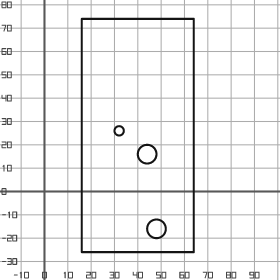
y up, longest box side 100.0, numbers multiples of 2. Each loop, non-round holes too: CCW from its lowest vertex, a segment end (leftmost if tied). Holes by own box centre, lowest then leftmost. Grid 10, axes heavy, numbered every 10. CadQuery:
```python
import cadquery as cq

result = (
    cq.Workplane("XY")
    .moveTo(16.0, -26.0)
    .lineTo(64.0, -26.0)
    .lineTo(64.0, 74.0)
    .lineTo(16.0, 74.0)
    .close()
    .moveTo(48.0, -16.0)
    .circle(4.0)
    .moveTo(44.0, 16.0)
    .circle(4.0)
    .moveTo(32.0, 26.0)
    .circle(2.0)
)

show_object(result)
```